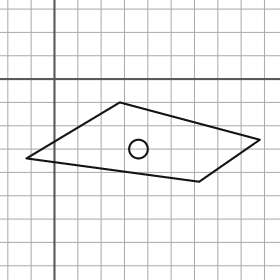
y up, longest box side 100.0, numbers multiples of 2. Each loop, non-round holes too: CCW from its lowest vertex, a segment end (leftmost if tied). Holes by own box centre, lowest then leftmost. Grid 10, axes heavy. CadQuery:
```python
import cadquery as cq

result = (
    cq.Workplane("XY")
    .moveTo(62.0, -44.0)
    .lineTo(88.0, -26.0)
    .lineTo(28.0, -10.0)
    .lineTo(-12.0, -34.0)
    .close()
    .moveTo(36.0, -30.0)
    .circle(4.0)
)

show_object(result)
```